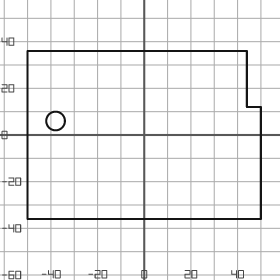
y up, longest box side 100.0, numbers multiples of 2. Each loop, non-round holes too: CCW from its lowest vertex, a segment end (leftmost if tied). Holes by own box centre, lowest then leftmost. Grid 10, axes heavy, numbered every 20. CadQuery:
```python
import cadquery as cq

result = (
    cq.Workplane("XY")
    .moveTo(-50.0, -36.0)
    .lineTo(50.0, -36.0)
    .lineTo(50.0, 12.0)
    .lineTo(44.0, 12.0)
    .lineTo(44.0, 36.0)
    .lineTo(-50.0, 36.0)
    .close()
    .moveTo(-38.0, 6.0)
    .circle(4.0)
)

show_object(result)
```